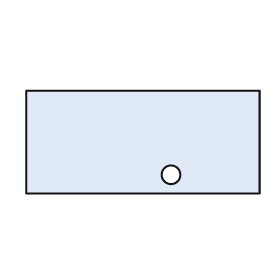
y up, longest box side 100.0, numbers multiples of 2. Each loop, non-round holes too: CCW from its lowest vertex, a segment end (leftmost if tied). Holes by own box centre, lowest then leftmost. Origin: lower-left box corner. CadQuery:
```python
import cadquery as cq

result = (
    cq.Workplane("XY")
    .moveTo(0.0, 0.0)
    .lineTo(100.0, 0.0)
    .lineTo(100.0, 44.0)
    .lineTo(0.0, 44.0)
    .close()
    .moveTo(62.0, 8.0)
    .circle(4.0)
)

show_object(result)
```